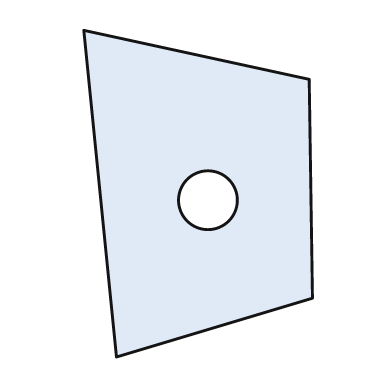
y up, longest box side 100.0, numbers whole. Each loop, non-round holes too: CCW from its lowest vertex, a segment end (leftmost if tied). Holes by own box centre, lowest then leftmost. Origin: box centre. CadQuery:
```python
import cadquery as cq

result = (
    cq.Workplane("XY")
    .moveTo(-25.0, -50.0)
    .lineTo(35.0, -32.0)
    .lineTo(34.0, 35.0)
    .lineTo(-35.0, 50.0)
    .close()
    .moveTo(3.0, -2.0)
    .circle(9.0)
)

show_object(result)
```